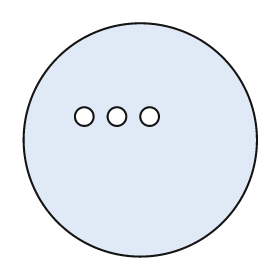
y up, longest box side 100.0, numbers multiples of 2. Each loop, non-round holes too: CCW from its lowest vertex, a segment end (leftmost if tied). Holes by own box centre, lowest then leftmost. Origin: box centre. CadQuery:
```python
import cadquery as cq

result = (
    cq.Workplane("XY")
    .moveTo(0.0, 0.0)
    .circle(50.0)
    .moveTo(-24.0, 10.0)
    .circle(4.0)
    .moveTo(-10.0, 10.0)
    .circle(4.0)
    .moveTo(4.0, 10.0)
    .circle(4.0)
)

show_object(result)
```